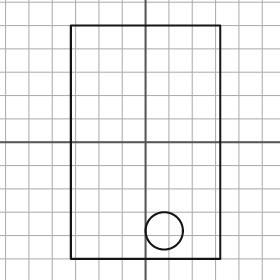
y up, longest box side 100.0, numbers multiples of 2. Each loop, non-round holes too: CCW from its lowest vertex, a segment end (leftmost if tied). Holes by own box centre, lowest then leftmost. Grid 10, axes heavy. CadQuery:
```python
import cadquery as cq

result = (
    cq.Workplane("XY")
    .moveTo(-32.0, -50.0)
    .lineTo(32.0, -50.0)
    .lineTo(32.0, 50.0)
    .lineTo(-32.0, 50.0)
    .close()
    .moveTo(8.0, -38.0)
    .circle(8.0)
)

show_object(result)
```